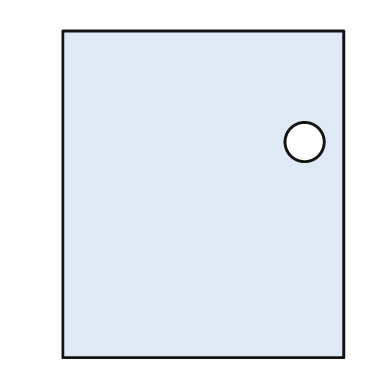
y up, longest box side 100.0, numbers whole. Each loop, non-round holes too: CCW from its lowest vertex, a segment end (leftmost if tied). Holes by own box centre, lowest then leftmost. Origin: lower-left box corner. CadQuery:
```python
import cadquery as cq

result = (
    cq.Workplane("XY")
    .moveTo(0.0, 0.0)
    .lineTo(86.0, 0.0)
    .lineTo(86.0, 100.0)
    .lineTo(0.0, 100.0)
    .close()
    .moveTo(74.0, 66.0)
    .circle(6.0)
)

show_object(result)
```